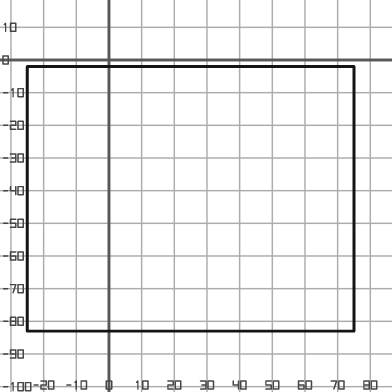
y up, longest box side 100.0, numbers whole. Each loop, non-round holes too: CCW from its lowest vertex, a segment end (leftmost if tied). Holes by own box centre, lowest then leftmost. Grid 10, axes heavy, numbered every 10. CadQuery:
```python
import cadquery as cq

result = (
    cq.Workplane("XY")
    .moveTo(-25.0, -83.0)
    .lineTo(75.0, -83.0)
    .lineTo(75.0, -2.0)
    .lineTo(-25.0, -2.0)
    .close()
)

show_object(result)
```